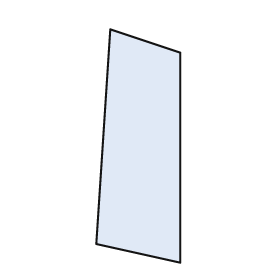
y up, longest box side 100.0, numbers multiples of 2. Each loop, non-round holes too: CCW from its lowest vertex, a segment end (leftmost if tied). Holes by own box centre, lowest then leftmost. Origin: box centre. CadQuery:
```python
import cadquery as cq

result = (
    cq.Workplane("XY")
    .moveTo(18.0, -50.0)
    .lineTo(18.0, 40.0)
    .lineTo(-12.0, 50.0)
    .lineTo(-18.0, -42.0)
    .close()
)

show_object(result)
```